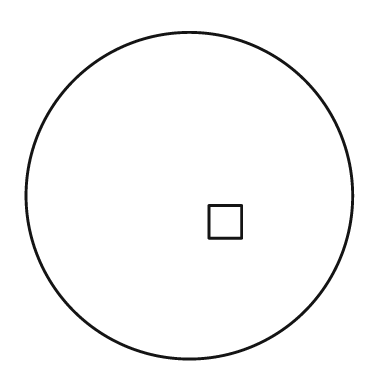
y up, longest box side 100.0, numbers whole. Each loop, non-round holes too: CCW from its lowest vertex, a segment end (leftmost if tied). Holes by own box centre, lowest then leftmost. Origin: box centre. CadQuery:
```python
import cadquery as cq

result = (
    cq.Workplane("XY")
    .moveTo(0.0, 0.0)
    .circle(50.0)
    .moveTo(6.0, -13.0)
    .lineTo(16.0, -13.0)
    .lineTo(16.0, -3.0)
    .lineTo(6.0, -3.0)
    .close()
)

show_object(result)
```